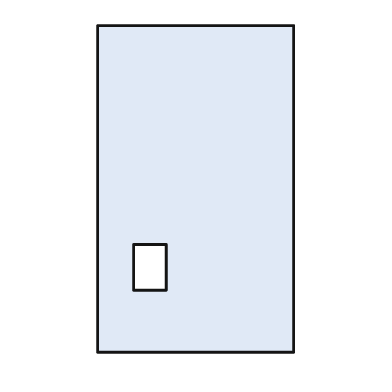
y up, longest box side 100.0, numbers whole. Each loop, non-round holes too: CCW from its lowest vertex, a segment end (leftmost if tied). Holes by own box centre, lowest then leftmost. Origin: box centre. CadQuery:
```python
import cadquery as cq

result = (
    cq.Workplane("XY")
    .moveTo(-30.0, -50.0)
    .lineTo(30.0, -50.0)
    .lineTo(30.0, 50.0)
    .lineTo(-30.0, 50.0)
    .close()
    .moveTo(-19.0, -31.0)
    .lineTo(-9.0, -31.0)
    .lineTo(-9.0, -17.0)
    .lineTo(-19.0, -17.0)
    .close()
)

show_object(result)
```